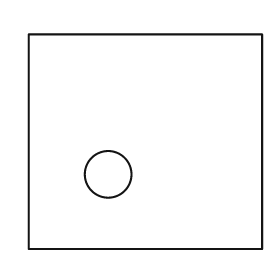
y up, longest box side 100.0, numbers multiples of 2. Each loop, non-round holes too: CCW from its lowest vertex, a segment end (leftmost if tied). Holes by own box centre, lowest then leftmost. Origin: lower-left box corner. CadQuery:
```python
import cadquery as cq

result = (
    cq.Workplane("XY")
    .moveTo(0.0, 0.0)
    .lineTo(100.0, 0.0)
    .lineTo(100.0, 92.0)
    .lineTo(0.0, 92.0)
    .close()
    .moveTo(34.0, 32.0)
    .circle(10.0)
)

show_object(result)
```